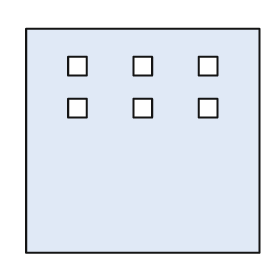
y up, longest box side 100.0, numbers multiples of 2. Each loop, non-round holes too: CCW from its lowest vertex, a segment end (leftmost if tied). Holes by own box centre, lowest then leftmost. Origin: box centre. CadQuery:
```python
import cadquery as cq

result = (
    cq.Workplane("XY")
    .moveTo(-50.0, -48.0)
    .lineTo(50.0, -48.0)
    .lineTo(50.0, 48.0)
    .lineTo(-50.0, 48.0)
    .close()
    .moveTo(-32.0, 10.0)
    .lineTo(-24.0, 10.0)
    .lineTo(-24.0, 18.0)
    .lineTo(-32.0, 18.0)
    .close()
    .moveTo(-4.0, 10.0)
    .lineTo(4.0, 10.0)
    .lineTo(4.0, 18.0)
    .lineTo(-4.0, 18.0)
    .close()
    .moveTo(24.0, 10.0)
    .lineTo(32.0, 10.0)
    .lineTo(32.0, 18.0)
    .lineTo(24.0, 18.0)
    .close()
    .moveTo(-32.0, 28.0)
    .lineTo(-24.0, 28.0)
    .lineTo(-24.0, 36.0)
    .lineTo(-32.0, 36.0)
    .close()
    .moveTo(-4.0, 28.0)
    .lineTo(4.0, 28.0)
    .lineTo(4.0, 36.0)
    .lineTo(-4.0, 36.0)
    .close()
    .moveTo(24.0, 28.0)
    .lineTo(32.0, 28.0)
    .lineTo(32.0, 36.0)
    .lineTo(24.0, 36.0)
    .close()
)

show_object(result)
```